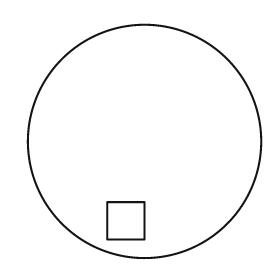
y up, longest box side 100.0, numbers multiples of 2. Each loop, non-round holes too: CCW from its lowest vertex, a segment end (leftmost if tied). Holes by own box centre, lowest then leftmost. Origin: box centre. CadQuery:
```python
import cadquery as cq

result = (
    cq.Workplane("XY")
    .moveTo(0.0, 0.0)
    .circle(50.0)
    .moveTo(-16.0, -42.0)
    .lineTo(0.0, -42.0)
    .lineTo(0.0, -26.0)
    .lineTo(-16.0, -26.0)
    .close()
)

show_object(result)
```